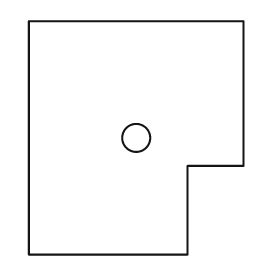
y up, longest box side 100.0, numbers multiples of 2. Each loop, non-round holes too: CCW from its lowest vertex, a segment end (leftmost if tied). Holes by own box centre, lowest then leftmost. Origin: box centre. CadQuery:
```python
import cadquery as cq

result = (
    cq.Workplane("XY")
    .moveTo(-46.0, -50.0)
    .lineTo(22.0, -50.0)
    .lineTo(22.0, -12.0)
    .lineTo(46.0, -12.0)
    .lineTo(46.0, 50.0)
    .lineTo(-46.0, 50.0)
    .close()
    .moveTo(0.0, 0.0)
    .circle(6.0)
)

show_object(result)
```